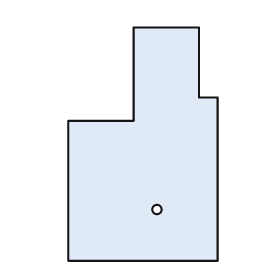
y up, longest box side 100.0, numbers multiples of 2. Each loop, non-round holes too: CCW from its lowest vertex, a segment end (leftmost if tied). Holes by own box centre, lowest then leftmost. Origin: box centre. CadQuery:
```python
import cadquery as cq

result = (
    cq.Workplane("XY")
    .moveTo(-32.0, -50.0)
    .lineTo(32.0, -50.0)
    .lineTo(32.0, 20.0)
    .lineTo(24.0, 20.0)
    .lineTo(24.0, 50.0)
    .lineTo(-4.0, 50.0)
    .lineTo(-4.0, 10.0)
    .lineTo(-32.0, 10.0)
    .close()
    .moveTo(6.0, -28.0)
    .circle(2.0)
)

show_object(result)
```